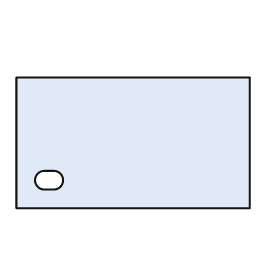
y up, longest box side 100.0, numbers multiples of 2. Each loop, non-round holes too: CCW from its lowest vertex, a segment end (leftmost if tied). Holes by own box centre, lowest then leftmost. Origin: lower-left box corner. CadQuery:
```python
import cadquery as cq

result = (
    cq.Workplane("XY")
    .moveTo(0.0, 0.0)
    .lineTo(100.0, 0.0)
    .lineTo(100.0, 56.0)
    .lineTo(0.0, 56.0)
    .close()
    .moveTo(12.0, 8.0)
    .lineTo(16.0, 8.0)
    .threePointArc((20.0, 12.0), (16.0, 16.0))
    .lineTo(12.0, 16.0)
    .threePointArc((8.0, 12.0), (12.0, 8.0))
    .close()
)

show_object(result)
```